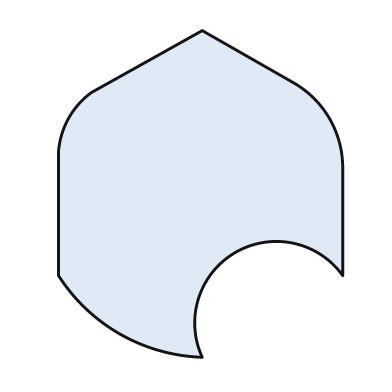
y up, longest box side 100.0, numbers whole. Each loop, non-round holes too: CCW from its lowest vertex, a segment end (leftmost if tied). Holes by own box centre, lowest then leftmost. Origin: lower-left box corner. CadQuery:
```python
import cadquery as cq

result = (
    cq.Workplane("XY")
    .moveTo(44.0, 0.0)
    .threePointArc((54.0, 32.0), (87.0, 25.0))
    .lineTo(87.0, 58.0)
    .threePointArc((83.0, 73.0), (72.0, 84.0))
    .lineTo(44.0, 100.0)
    .lineTo(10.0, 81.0)
    .threePointArc((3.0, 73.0), (0.0, 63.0))
    .lineTo(0.0, 25.0)
    .threePointArc((19.0, 7.0), (44.0, 0.0))
    .close()
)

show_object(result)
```